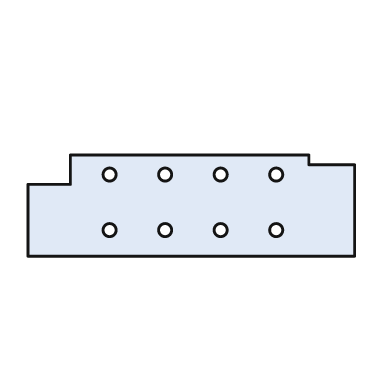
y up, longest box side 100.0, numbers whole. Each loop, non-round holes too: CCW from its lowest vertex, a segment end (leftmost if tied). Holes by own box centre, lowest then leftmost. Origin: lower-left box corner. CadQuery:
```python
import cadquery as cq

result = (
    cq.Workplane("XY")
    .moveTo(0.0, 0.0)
    .lineTo(100.0, 0.0)
    .lineTo(100.0, 28.0)
    .lineTo(86.0, 28.0)
    .lineTo(86.0, 31.0)
    .lineTo(13.0, 31.0)
    .lineTo(13.0, 22.0)
    .lineTo(0.0, 22.0)
    .close()
    .moveTo(25.0, 8.0)
    .circle(2.0)
    .moveTo(42.0, 8.0)
    .circle(2.0)
    .moveTo(59.0, 8.0)
    .circle(2.0)
    .moveTo(76.0, 8.0)
    .circle(2.0)
    .moveTo(25.0, 25.0)
    .circle(2.0)
    .moveTo(42.0, 25.0)
    .circle(2.0)
    .moveTo(59.0, 25.0)
    .circle(2.0)
    .moveTo(76.0, 25.0)
    .circle(2.0)
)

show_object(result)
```